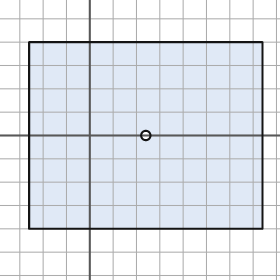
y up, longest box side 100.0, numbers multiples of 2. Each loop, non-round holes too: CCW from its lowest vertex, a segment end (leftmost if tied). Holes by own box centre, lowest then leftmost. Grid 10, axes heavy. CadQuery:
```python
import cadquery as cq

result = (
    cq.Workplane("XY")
    .moveTo(-26.0, -40.0)
    .lineTo(74.0, -40.0)
    .lineTo(74.0, 40.0)
    .lineTo(-26.0, 40.0)
    .close()
    .moveTo(24.0, 0.0)
    .circle(2.0)
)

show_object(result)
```